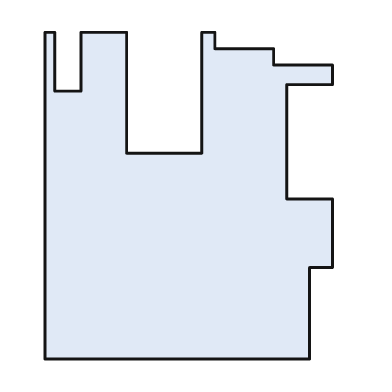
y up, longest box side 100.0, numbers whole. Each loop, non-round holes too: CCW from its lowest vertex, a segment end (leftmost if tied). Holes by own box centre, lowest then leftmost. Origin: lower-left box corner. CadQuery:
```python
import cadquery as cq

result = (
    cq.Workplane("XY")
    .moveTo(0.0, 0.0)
    .lineTo(81.0, 0.0)
    .lineTo(81.0, 28.0)
    .lineTo(88.0, 28.0)
    .lineTo(88.0, 49.0)
    .lineTo(74.0, 49.0)
    .lineTo(74.0, 84.0)
    .lineTo(88.0, 84.0)
    .lineTo(88.0, 90.0)
    .lineTo(70.0, 90.0)
    .lineTo(70.0, 95.0)
    .lineTo(52.0, 95.0)
    .lineTo(52.0, 100.0)
    .lineTo(48.0, 100.0)
    .lineTo(48.0, 63.0)
    .lineTo(25.0, 63.0)
    .lineTo(25.0, 100.0)
    .lineTo(11.0, 100.0)
    .lineTo(11.0, 82.0)
    .lineTo(3.0, 82.0)
    .lineTo(3.0, 100.0)
    .lineTo(0.0, 100.0)
    .close()
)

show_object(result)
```